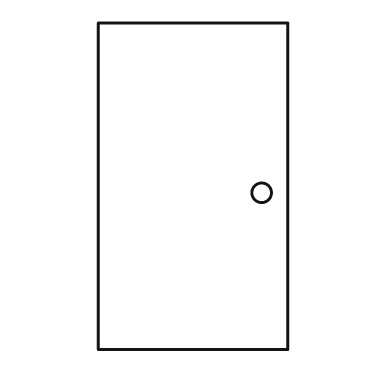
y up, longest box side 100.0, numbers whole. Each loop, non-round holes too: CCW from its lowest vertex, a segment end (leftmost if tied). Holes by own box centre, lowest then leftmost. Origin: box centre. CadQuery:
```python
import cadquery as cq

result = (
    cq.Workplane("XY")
    .moveTo(-29.0, -50.0)
    .lineTo(29.0, -50.0)
    .lineTo(29.0, 50.0)
    .lineTo(-29.0, 50.0)
    .close()
    .moveTo(21.0, -2.0)
    .circle(3.0)
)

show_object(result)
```